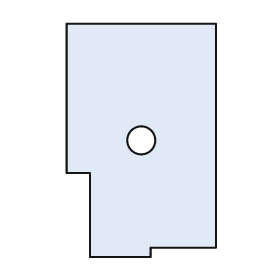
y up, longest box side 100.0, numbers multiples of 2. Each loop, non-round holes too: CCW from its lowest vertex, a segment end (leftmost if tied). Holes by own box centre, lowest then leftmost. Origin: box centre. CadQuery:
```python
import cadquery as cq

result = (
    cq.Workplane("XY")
    .moveTo(-22.0, -50.0)
    .lineTo(4.0, -50.0)
    .lineTo(4.0, -46.0)
    .lineTo(32.0, -46.0)
    .lineTo(32.0, 50.0)
    .lineTo(-32.0, 50.0)
    .lineTo(-32.0, -14.0)
    .lineTo(-22.0, -14.0)
    .close()
    .moveTo(0.0, 0.0)
    .circle(6.0)
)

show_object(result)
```